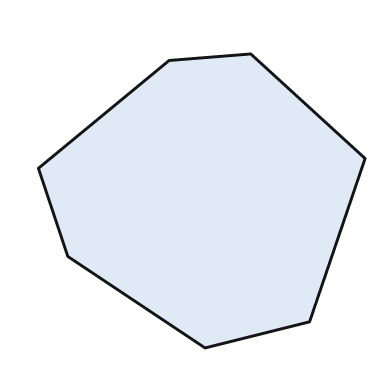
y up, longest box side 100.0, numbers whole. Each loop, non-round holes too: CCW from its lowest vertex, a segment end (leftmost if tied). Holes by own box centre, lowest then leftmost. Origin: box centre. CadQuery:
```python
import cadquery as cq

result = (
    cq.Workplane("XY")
    .moveTo(1.0, -45.0)
    .lineTo(33.0, -37.0)
    .lineTo(50.0, 13.0)
    .lineTo(15.0, 45.0)
    .lineTo(-10.0, 43.0)
    .lineTo(-50.0, 10.0)
    .lineTo(-41.0, -17.0)
    .close()
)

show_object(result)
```